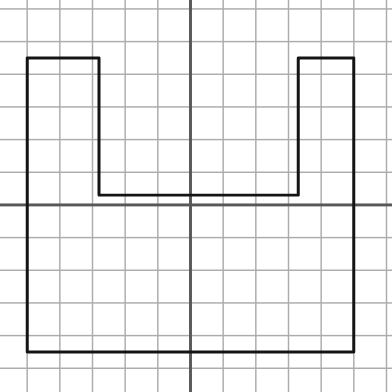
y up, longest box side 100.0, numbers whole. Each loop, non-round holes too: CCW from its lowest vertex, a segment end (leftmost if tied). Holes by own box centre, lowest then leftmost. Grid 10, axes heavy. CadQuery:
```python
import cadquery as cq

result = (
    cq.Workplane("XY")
    .moveTo(-50.0, -45.0)
    .lineTo(50.0, -45.0)
    .lineTo(50.0, 45.0)
    .lineTo(33.0, 45.0)
    .lineTo(33.0, 3.0)
    .lineTo(-28.0, 3.0)
    .lineTo(-28.0, 45.0)
    .lineTo(-50.0, 45.0)
    .close()
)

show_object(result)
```